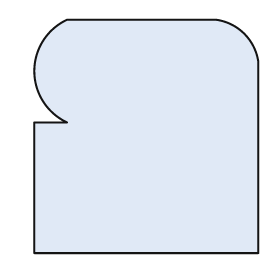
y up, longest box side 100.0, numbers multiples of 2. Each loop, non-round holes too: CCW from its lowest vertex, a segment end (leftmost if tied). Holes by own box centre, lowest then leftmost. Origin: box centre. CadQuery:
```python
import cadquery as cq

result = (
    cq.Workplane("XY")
    .moveTo(-48.0, -50.0)
    .lineTo(48.0, -50.0)
    .lineTo(48.0, 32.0)
    .threePointArc((42.0, 44.0), (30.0, 50.0))
    .lineTo(-34.0, 50.0)
    .threePointArc((-48.0, 28.0), (-34.0, 6.0))
    .lineTo(-48.0, 6.0)
    .close()
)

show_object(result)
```